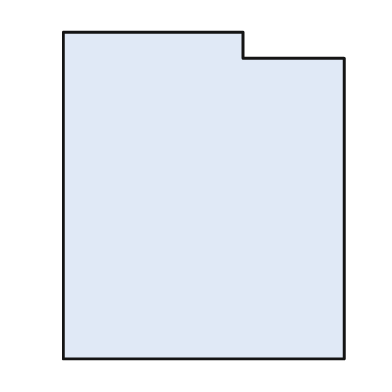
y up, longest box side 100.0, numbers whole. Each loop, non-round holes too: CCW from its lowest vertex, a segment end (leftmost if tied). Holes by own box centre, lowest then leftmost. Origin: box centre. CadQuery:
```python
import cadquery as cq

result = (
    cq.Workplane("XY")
    .moveTo(-43.0, -50.0)
    .lineTo(43.0, -50.0)
    .lineTo(43.0, 42.0)
    .lineTo(12.0, 42.0)
    .lineTo(12.0, 50.0)
    .lineTo(-43.0, 50.0)
    .close()
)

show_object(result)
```